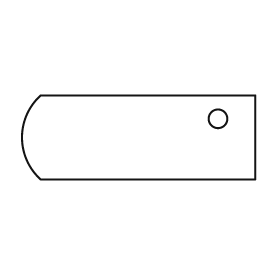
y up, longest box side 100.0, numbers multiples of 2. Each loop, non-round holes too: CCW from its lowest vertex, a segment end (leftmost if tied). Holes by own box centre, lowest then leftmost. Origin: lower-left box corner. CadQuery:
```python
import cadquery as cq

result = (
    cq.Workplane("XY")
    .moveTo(8.0, 0.0)
    .lineTo(100.0, 0.0)
    .lineTo(100.0, 36.0)
    .lineTo(8.0, 36.0)
    .threePointArc((0.0, 18.0), (8.0, 0.0))
    .close()
    .moveTo(84.0, 26.0)
    .circle(4.0)
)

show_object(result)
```